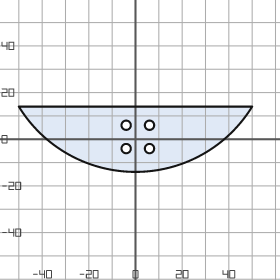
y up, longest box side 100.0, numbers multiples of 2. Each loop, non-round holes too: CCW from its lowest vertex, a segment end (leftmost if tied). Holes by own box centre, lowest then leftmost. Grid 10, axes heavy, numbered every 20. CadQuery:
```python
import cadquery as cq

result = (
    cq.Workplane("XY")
    .moveTo(-50.0, 14.0)
    .threePointArc((0.0, -14.0), (50.0, 14.0))
    .close()
    .moveTo(-4.0, -4.0)
    .circle(2.0)
    .moveTo(6.0, -4.0)
    .circle(2.0)
    .moveTo(-4.0, 6.0)
    .circle(2.0)
    .moveTo(6.0, 6.0)
    .circle(2.0)
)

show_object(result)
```